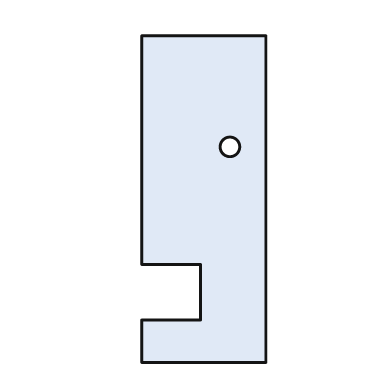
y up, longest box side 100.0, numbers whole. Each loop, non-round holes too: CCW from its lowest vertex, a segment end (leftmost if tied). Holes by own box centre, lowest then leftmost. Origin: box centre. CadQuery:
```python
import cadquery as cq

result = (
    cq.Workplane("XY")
    .moveTo(-19.0, -50.0)
    .lineTo(19.0, -50.0)
    .lineTo(19.0, 50.0)
    .lineTo(-19.0, 50.0)
    .lineTo(-19.0, -20.0)
    .lineTo(-1.0, -20.0)
    .lineTo(-1.0, -37.0)
    .lineTo(-19.0, -37.0)
    .close()
    .moveTo(8.0, 16.0)
    .circle(3.0)
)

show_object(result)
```